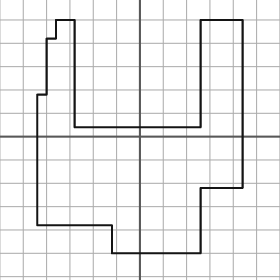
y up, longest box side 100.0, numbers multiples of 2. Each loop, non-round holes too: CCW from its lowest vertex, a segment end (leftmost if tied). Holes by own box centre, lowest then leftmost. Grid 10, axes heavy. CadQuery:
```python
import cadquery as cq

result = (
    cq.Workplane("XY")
    .moveTo(-12.0, -50.0)
    .lineTo(26.0, -50.0)
    .lineTo(26.0, -22.0)
    .lineTo(44.0, -22.0)
    .lineTo(44.0, 50.0)
    .lineTo(26.0, 50.0)
    .lineTo(26.0, 4.0)
    .lineTo(-28.0, 4.0)
    .lineTo(-28.0, 50.0)
    .lineTo(-36.0, 50.0)
    .lineTo(-36.0, 42.0)
    .lineTo(-40.0, 42.0)
    .lineTo(-40.0, 18.0)
    .lineTo(-44.0, 18.0)
    .lineTo(-44.0, -38.0)
    .lineTo(-12.0, -38.0)
    .close()
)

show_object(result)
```